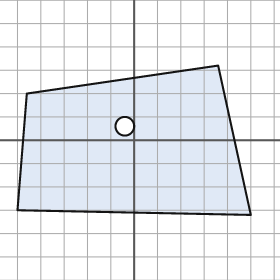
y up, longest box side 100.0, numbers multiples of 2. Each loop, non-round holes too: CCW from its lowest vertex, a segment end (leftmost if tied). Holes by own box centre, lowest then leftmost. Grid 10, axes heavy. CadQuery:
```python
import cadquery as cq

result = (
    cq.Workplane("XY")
    .moveTo(50.0, -32.0)
    .lineTo(36.0, 32.0)
    .lineTo(-46.0, 20.0)
    .lineTo(-50.0, -30.0)
    .close()
    .moveTo(-4.0, 6.0)
    .circle(4.0)
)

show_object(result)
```